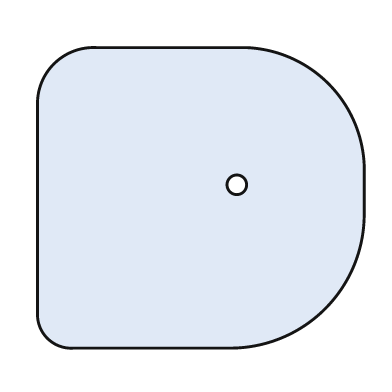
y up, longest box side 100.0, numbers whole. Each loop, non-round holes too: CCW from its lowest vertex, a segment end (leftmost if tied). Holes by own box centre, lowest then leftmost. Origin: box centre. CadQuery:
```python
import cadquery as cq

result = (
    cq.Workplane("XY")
    .moveTo(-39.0, -46.0)
    .lineTo(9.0, -46.0)
    .threePointArc((38.0, -34.0), (50.0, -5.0))
    .lineTo(50.0, 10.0)
    .threePointArc((39.0, 35.0), (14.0, 46.0))
    .lineTo(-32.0, 46.0)
    .threePointArc((-45.0, 41.0), (-50.0, 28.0))
    .lineTo(-50.0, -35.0)
    .threePointArc((-47.0, -43.0), (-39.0, -46.0))
    .close()
    .moveTo(11.0, 4.0)
    .circle(3.0)
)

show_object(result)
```